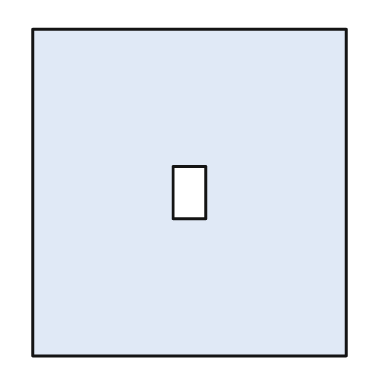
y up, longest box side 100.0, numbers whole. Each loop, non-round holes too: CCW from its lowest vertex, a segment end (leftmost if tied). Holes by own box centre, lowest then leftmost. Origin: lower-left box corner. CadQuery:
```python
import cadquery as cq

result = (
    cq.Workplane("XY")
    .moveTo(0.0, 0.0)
    .lineTo(96.0, 0.0)
    .lineTo(96.0, 100.0)
    .lineTo(0.0, 100.0)
    .close()
    .moveTo(43.0, 42.0)
    .lineTo(53.0, 42.0)
    .lineTo(53.0, 58.0)
    .lineTo(43.0, 58.0)
    .close()
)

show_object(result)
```